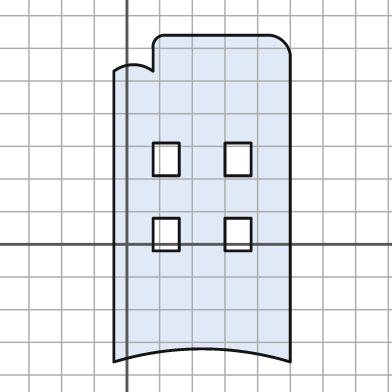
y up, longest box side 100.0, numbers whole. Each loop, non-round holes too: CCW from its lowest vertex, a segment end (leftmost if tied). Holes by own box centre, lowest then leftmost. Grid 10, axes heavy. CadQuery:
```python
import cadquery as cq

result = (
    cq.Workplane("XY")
    .moveTo(-4.0, -36.0)
    .threePointArc((23.0, -32.0), (50.0, -36.0))
    .lineTo(50.0, 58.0)
    .threePointArc((48.0, 62.0), (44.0, 64.0))
    .lineTo(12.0, 64.0)
    .threePointArc((9.0, 63.0), (8.0, 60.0))
    .lineTo(8.0, 53.0)
    .threePointArc((2.0, 55.0), (-4.0, 53.0))
    .close()
    .moveTo(8.0, -2.0)
    .lineTo(16.0, -2.0)
    .lineTo(16.0, 8.0)
    .lineTo(8.0, 8.0)
    .close()
    .moveTo(30.0, -2.0)
    .lineTo(38.0, -2.0)
    .lineTo(38.0, 8.0)
    .lineTo(30.0, 8.0)
    .close()
    .moveTo(8.0, 21.0)
    .lineTo(16.0, 21.0)
    .lineTo(16.0, 31.0)
    .lineTo(8.0, 31.0)
    .close()
    .moveTo(30.0, 21.0)
    .lineTo(38.0, 21.0)
    .lineTo(38.0, 31.0)
    .lineTo(30.0, 31.0)
    .close()
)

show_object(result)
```